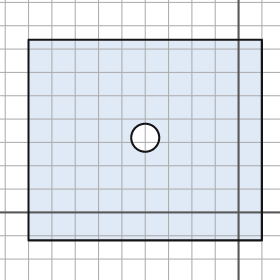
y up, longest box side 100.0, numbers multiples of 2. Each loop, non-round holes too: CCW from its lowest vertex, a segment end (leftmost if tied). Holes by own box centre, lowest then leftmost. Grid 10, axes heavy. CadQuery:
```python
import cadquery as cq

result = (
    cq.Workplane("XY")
    .moveTo(-90.0, -12.0)
    .lineTo(10.0, -12.0)
    .lineTo(10.0, 74.0)
    .lineTo(-90.0, 74.0)
    .close()
    .moveTo(-40.0, 32.0)
    .circle(6.0)
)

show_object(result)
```